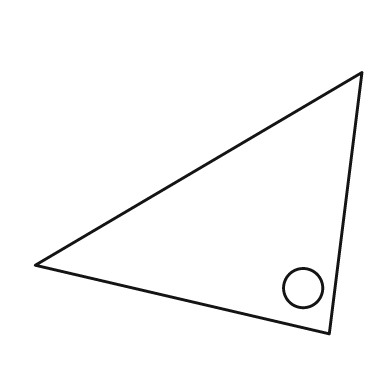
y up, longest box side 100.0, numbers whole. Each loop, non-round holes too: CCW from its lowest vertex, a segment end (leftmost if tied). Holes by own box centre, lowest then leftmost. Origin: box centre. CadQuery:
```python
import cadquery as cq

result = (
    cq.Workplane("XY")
    .moveTo(40.0, -40.0)
    .lineTo(50.0, 40.0)
    .lineTo(-50.0, -19.0)
    .close()
    .moveTo(32.0, -26.0)
    .circle(6.0)
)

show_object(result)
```